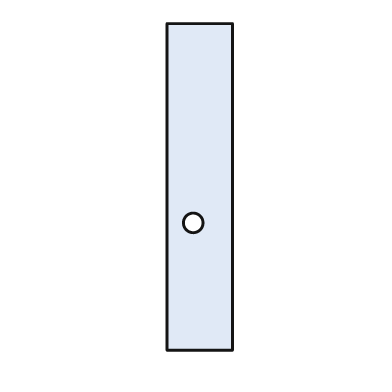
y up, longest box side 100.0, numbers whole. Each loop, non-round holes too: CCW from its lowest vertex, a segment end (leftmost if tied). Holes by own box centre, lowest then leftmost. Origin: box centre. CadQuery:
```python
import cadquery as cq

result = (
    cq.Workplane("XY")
    .moveTo(-10.0, -50.0)
    .lineTo(10.0, -50.0)
    .lineTo(10.0, 50.0)
    .lineTo(-10.0, 50.0)
    .close()
    .moveTo(-2.0, -11.0)
    .circle(3.0)
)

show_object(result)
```